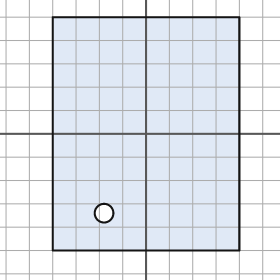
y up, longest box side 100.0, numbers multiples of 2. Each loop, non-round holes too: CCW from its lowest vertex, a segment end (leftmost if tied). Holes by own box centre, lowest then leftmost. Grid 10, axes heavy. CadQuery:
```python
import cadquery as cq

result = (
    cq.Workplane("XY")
    .moveTo(-40.0, -50.0)
    .lineTo(40.0, -50.0)
    .lineTo(40.0, 50.0)
    .lineTo(-40.0, 50.0)
    .close()
    .moveTo(-18.0, -34.0)
    .circle(4.0)
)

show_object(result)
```